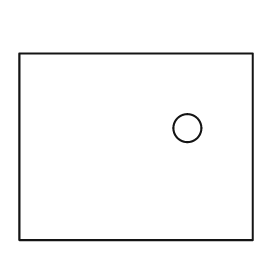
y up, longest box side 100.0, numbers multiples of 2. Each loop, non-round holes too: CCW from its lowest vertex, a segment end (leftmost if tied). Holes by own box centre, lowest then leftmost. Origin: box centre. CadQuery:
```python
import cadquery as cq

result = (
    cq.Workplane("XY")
    .moveTo(-50.0, -40.0)
    .lineTo(50.0, -40.0)
    .lineTo(50.0, 40.0)
    .lineTo(-50.0, 40.0)
    .close()
    .moveTo(22.0, 8.0)
    .circle(6.0)
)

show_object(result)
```